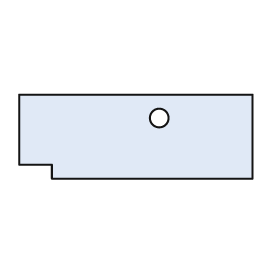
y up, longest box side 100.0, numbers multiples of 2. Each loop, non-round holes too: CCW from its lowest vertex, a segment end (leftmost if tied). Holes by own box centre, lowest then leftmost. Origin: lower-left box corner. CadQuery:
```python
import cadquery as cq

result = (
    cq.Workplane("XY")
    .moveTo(14.0, 0.0)
    .lineTo(100.0, 0.0)
    .lineTo(100.0, 36.0)
    .lineTo(0.0, 36.0)
    .lineTo(0.0, 6.0)
    .lineTo(14.0, 6.0)
    .close()
    .moveTo(60.0, 26.0)
    .circle(4.0)
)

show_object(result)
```